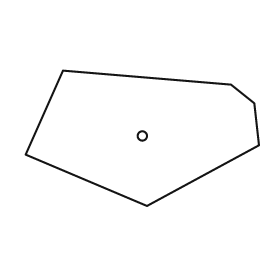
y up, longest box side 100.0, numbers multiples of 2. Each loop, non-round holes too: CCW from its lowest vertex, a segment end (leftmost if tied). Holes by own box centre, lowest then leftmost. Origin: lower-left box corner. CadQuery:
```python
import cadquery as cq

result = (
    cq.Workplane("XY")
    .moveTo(52.0, 0.0)
    .lineTo(100.0, 26.0)
    .lineTo(98.0, 44.0)
    .lineTo(88.0, 52.0)
    .lineTo(16.0, 58.0)
    .lineTo(0.0, 22.0)
    .close()
    .moveTo(50.0, 30.0)
    .circle(2.0)
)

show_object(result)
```